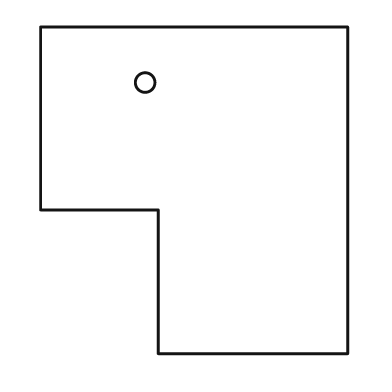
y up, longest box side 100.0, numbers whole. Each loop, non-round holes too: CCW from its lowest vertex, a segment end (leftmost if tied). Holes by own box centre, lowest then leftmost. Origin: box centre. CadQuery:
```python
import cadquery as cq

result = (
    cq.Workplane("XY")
    .moveTo(-11.0, -50.0)
    .lineTo(47.0, -50.0)
    .lineTo(47.0, 50.0)
    .lineTo(-47.0, 50.0)
    .lineTo(-47.0, -6.0)
    .lineTo(-11.0, -6.0)
    .close()
    .moveTo(-15.0, 33.0)
    .circle(3.0)
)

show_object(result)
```